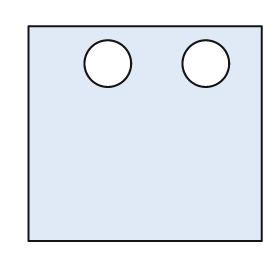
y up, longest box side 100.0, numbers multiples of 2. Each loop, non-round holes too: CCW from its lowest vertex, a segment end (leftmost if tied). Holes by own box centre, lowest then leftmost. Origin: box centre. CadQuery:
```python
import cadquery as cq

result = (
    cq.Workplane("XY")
    .moveTo(-50.0, -46.0)
    .lineTo(50.0, -46.0)
    .lineTo(50.0, 46.0)
    .lineTo(-50.0, 46.0)
    .close()
    .moveTo(-16.0, 30.0)
    .circle(10.0)
    .moveTo(26.0, 30.0)
    .circle(10.0)
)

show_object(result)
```